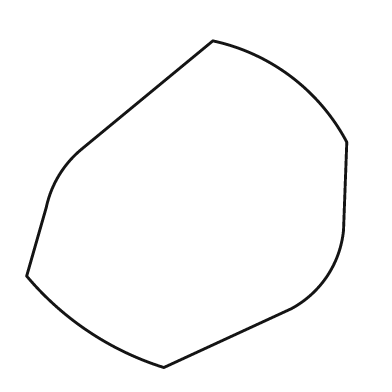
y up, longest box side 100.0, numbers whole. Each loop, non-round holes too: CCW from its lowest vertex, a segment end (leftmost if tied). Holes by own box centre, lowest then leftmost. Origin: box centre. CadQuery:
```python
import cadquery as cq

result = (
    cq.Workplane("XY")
    .moveTo(-7.0, -50.0)
    .lineTo(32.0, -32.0)
    .threePointArc((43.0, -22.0), (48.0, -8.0))
    .lineTo(49.0, 19.0)
    .threePointArc((32.0, 39.0), (8.0, 50.0))
    .lineTo(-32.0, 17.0)
    .threePointArc((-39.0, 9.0), (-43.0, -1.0))
    .lineTo(-49.0, -22.0)
    .threePointArc((-30.0, -39.0), (-7.0, -50.0))
    .close()
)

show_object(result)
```